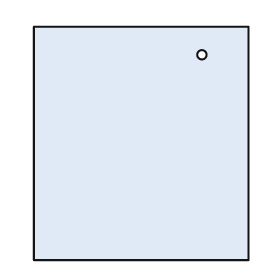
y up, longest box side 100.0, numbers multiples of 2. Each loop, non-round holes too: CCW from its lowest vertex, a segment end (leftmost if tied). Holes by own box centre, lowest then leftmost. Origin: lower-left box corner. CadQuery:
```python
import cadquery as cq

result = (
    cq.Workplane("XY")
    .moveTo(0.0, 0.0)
    .lineTo(92.0, 0.0)
    .lineTo(92.0, 100.0)
    .lineTo(0.0, 100.0)
    .close()
    .moveTo(72.0, 88.0)
    .circle(2.0)
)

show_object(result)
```